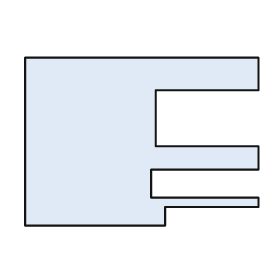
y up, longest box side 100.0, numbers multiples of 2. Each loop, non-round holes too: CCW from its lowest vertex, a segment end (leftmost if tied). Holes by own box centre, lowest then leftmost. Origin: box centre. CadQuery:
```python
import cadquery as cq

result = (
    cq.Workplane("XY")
    .moveTo(-50.0, -36.0)
    .lineTo(10.0, -36.0)
    .lineTo(10.0, -28.0)
    .lineTo(50.0, -28.0)
    .lineTo(50.0, -24.0)
    .lineTo(4.0, -24.0)
    .lineTo(4.0, -12.0)
    .lineTo(50.0, -12.0)
    .lineTo(50.0, -2.0)
    .lineTo(6.0, -2.0)
    .lineTo(6.0, 22.0)
    .lineTo(50.0, 22.0)
    .lineTo(50.0, 36.0)
    .lineTo(-50.0, 36.0)
    .close()
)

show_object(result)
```